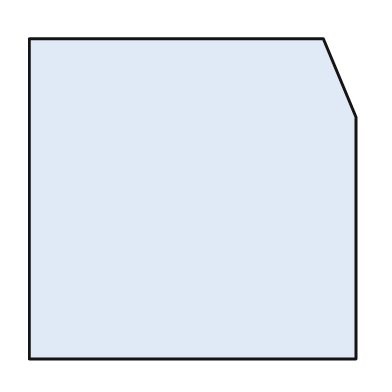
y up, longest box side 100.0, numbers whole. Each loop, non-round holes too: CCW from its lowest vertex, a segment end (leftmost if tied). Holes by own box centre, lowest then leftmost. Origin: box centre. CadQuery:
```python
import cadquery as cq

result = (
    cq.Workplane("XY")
    .moveTo(-50.0, -49.0)
    .lineTo(50.0, -49.0)
    .lineTo(50.0, 25.0)
    .lineTo(40.0, 49.0)
    .lineTo(-50.0, 49.0)
    .close()
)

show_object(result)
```